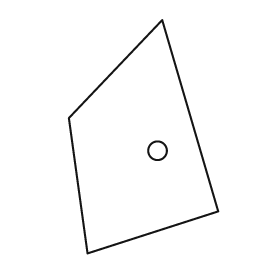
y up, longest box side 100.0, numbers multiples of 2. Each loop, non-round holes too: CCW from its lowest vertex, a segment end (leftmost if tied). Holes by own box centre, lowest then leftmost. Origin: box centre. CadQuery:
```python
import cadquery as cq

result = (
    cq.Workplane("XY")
    .moveTo(-24.0, -50.0)
    .lineTo(32.0, -32.0)
    .lineTo(8.0, 50.0)
    .lineTo(-32.0, 8.0)
    .close()
    .moveTo(6.0, -6.0)
    .circle(4.0)
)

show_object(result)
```